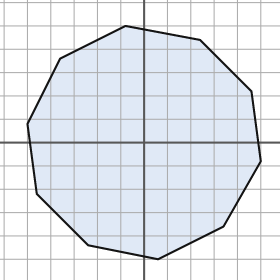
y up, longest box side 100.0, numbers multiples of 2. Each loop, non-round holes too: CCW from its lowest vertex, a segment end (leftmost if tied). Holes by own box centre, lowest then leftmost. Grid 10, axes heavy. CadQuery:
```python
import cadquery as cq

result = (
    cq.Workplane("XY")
    .moveTo(6.0, -50.0)
    .lineTo(34.0, -36.0)
    .lineTo(50.0, -8.0)
    .lineTo(46.0, 22.0)
    .lineTo(24.0, 44.0)
    .lineTo(-8.0, 50.0)
    .lineTo(-36.0, 36.0)
    .lineTo(-50.0, 8.0)
    .lineTo(-46.0, -22.0)
    .lineTo(-24.0, -44.0)
    .close()
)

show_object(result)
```